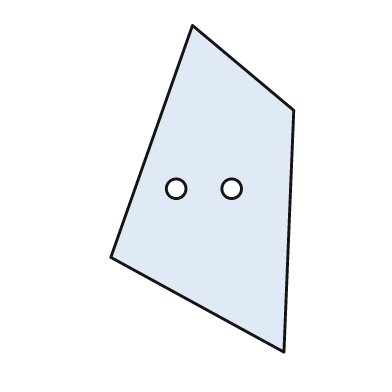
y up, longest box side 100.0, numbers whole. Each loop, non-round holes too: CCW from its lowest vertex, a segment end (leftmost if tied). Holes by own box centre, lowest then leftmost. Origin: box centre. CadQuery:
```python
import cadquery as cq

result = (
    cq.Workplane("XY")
    .moveTo(25.0, -50.0)
    .lineTo(28.0, 24.0)
    .lineTo(-3.0, 50.0)
    .lineTo(-28.0, -21.0)
    .close()
    .moveTo(-8.0, 0.0)
    .circle(3.0)
    .moveTo(9.0, 0.0)
    .circle(3.0)
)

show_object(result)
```